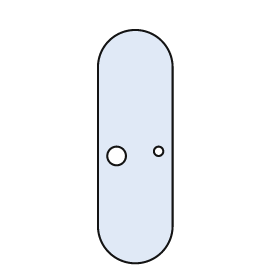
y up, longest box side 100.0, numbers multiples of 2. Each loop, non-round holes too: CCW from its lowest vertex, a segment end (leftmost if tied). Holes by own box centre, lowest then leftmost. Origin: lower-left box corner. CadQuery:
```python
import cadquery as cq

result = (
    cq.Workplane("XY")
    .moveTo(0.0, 16.0)
    .threePointArc((16.0, 0.0), (32.0, 16.0))
    .lineTo(32.0, 84.0)
    .threePointArc((16.0, 100.0), (0.0, 84.0))
    .close()
    .moveTo(8.0, 46.0)
    .circle(4.0)
    .moveTo(26.0, 48.0)
    .circle(2.0)
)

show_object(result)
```